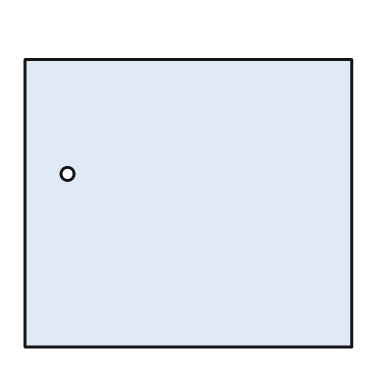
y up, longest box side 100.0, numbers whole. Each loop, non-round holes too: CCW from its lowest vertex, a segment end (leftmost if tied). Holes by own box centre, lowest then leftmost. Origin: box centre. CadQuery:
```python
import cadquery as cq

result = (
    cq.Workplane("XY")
    .moveTo(-50.0, -44.0)
    .lineTo(50.0, -44.0)
    .lineTo(50.0, 44.0)
    .lineTo(-50.0, 44.0)
    .close()
    .moveTo(-37.0, 9.0)
    .circle(2.0)
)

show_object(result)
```